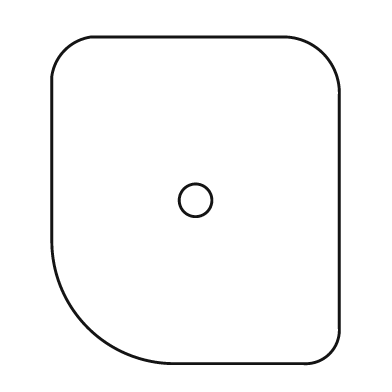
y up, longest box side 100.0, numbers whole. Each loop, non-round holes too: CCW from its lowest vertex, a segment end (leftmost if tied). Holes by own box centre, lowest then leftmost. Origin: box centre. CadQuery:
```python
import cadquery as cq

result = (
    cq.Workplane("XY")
    .moveTo(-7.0, -50.0)
    .lineTo(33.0, -50.0)
    .threePointArc((41.0, -47.0), (44.0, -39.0))
    .lineTo(44.0, 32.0)
    .threePointArc((39.0, 45.0), (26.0, 50.0))
    .lineTo(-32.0, 50.0)
    .threePointArc((-40.0, 46.0), (-44.0, 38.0))
    .lineTo(-44.0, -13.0)
    .threePointArc((-33.0, -39.0), (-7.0, -50.0))
    .close()
    .moveTo(0.0, 0.0)
    .circle(5.0)
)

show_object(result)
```